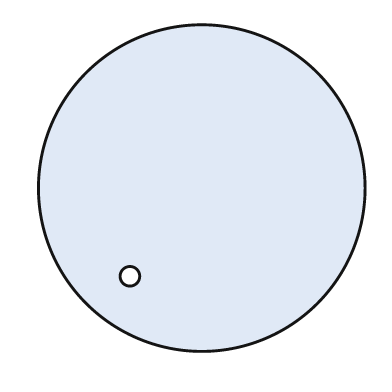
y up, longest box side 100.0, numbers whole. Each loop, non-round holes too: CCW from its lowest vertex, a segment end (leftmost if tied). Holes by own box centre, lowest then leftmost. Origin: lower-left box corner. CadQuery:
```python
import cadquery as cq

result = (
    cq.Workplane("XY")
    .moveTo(50.0, 50.0)
    .circle(50.0)
    .moveTo(28.0, 23.0)
    .circle(3.0)
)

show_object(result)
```